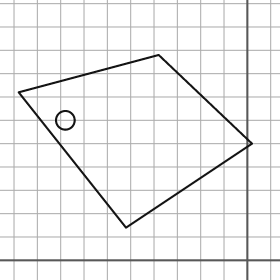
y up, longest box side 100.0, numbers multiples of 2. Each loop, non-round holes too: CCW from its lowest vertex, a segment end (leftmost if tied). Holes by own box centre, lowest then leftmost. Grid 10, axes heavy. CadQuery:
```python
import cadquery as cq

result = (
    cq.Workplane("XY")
    .moveTo(-52.0, 14.0)
    .lineTo(2.0, 50.0)
    .lineTo(-38.0, 88.0)
    .lineTo(-98.0, 72.0)
    .close()
    .moveTo(-78.0, 60.0)
    .circle(4.0)
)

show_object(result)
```